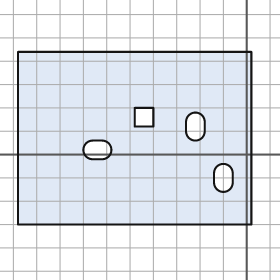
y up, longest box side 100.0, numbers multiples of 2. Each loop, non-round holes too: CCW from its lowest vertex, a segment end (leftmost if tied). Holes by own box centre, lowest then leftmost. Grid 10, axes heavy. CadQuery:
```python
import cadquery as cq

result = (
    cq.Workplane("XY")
    .moveTo(-98.0, -30.0)
    .lineTo(2.0, -30.0)
    .lineTo(2.0, 44.0)
    .lineTo(-98.0, 44.0)
    .close()
    .moveTo(-14.0, -12.0)
    .threePointArc((-10.0, -16.0), (-6.0, -12.0))
    .lineTo(-6.0, -8.0)
    .threePointArc((-10.0, -4.0), (-14.0, -8.0))
    .close()
    .moveTo(-66.0, -2.0)
    .lineTo(-62.0, -2.0)
    .threePointArc((-58.0, 2.0), (-62.0, 6.0))
    .lineTo(-66.0, 6.0)
    .threePointArc((-70.0, 2.0), (-66.0, -2.0))
    .close()
    .moveTo(-26.0, 10.0)
    .threePointArc((-22.0, 6.0), (-18.0, 10.0))
    .lineTo(-18.0, 14.0)
    .threePointArc((-22.0, 18.0), (-26.0, 14.0))
    .close()
    .moveTo(-48.0, 12.0)
    .lineTo(-40.0, 12.0)
    .lineTo(-40.0, 20.0)
    .lineTo(-48.0, 20.0)
    .close()
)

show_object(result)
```